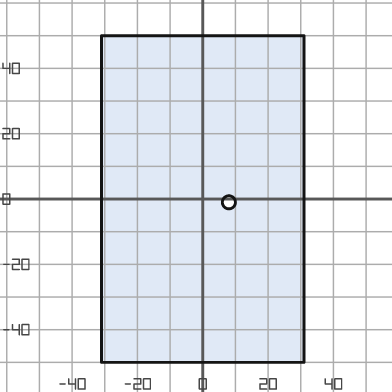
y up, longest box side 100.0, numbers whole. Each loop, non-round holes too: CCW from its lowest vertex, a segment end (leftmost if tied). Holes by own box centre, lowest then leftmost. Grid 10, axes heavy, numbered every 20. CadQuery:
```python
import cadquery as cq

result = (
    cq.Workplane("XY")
    .moveTo(-31.0, -50.0)
    .lineTo(31.0, -50.0)
    .lineTo(31.0, 50.0)
    .lineTo(-31.0, 50.0)
    .close()
    .moveTo(8.0, -1.0)
    .circle(2.0)
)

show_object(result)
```